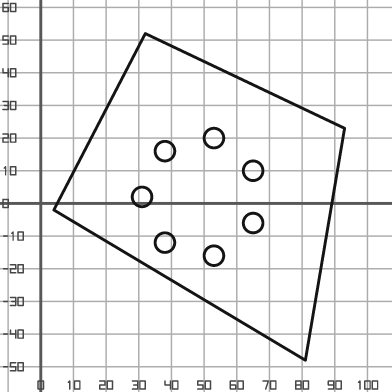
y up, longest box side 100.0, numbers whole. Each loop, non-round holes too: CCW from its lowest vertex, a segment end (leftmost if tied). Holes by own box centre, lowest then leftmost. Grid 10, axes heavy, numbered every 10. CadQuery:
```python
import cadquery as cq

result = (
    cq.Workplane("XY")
    .moveTo(81.0, -48.0)
    .lineTo(93.0, 23.0)
    .lineTo(32.0, 52.0)
    .lineTo(4.0, -2.0)
    .close()
    .moveTo(53.0, -16.0)
    .circle(3.0)
    .moveTo(38.0, -12.0)
    .circle(3.0)
    .moveTo(65.0, -6.0)
    .circle(3.0)
    .moveTo(31.0, 2.0)
    .circle(3.0)
    .moveTo(65.0, 10.0)
    .circle(3.0)
    .moveTo(38.0, 16.0)
    .circle(3.0)
    .moveTo(53.0, 20.0)
    .circle(3.0)
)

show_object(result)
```